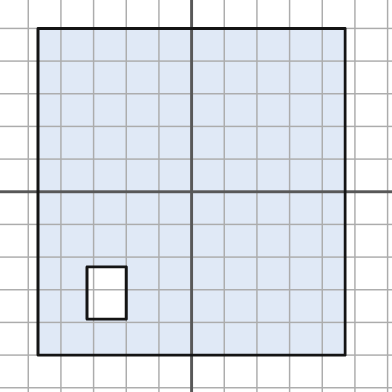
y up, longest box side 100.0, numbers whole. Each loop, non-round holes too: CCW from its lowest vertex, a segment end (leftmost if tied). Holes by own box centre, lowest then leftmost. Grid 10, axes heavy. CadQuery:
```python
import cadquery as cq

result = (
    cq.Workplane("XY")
    .moveTo(-47.0, -50.0)
    .lineTo(47.0, -50.0)
    .lineTo(47.0, 50.0)
    .lineTo(-47.0, 50.0)
    .close()
    .moveTo(-32.0, -39.0)
    .lineTo(-20.0, -39.0)
    .lineTo(-20.0, -23.0)
    .lineTo(-32.0, -23.0)
    .close()
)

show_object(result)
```